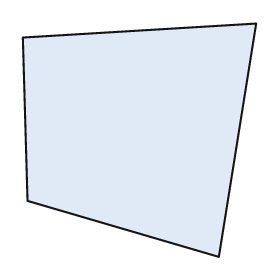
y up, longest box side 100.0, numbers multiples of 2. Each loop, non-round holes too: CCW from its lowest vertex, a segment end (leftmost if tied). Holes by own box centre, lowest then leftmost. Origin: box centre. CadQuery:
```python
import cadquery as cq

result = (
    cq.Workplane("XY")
    .moveTo(34.0, -50.0)
    .lineTo(50.0, 50.0)
    .lineTo(-50.0, 44.0)
    .lineTo(-48.0, -26.0)
    .close()
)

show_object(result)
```